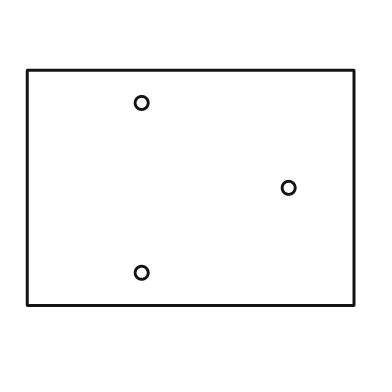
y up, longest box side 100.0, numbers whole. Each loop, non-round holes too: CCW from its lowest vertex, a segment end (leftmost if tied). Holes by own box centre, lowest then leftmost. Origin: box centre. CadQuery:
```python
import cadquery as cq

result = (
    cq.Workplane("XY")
    .moveTo(-50.0, -36.0)
    .lineTo(50.0, -36.0)
    .lineTo(50.0, 36.0)
    .lineTo(-50.0, 36.0)
    .close()
    .moveTo(-15.0, -26.0)
    .circle(2.0)
    .moveTo(30.0, 0.0)
    .circle(2.0)
    .moveTo(-15.0, 26.0)
    .circle(2.0)
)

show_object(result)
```